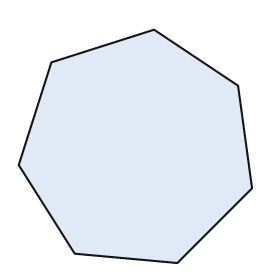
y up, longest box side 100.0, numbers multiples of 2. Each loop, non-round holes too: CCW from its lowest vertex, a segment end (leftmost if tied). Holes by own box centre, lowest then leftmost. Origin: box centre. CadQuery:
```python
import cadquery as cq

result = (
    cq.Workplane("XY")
    .moveTo(18.0, -50.0)
    .lineTo(50.0, -18.0)
    .lineTo(44.0, 26.0)
    .lineTo(8.0, 50.0)
    .lineTo(-36.0, 36.0)
    .lineTo(-50.0, -8.0)
    .lineTo(-26.0, -46.0)
    .close()
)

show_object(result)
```